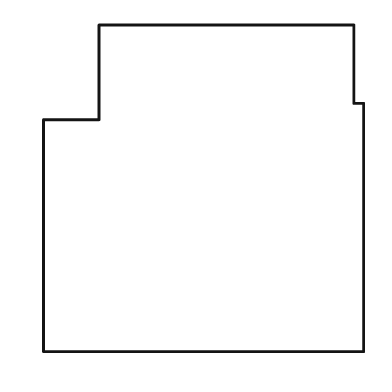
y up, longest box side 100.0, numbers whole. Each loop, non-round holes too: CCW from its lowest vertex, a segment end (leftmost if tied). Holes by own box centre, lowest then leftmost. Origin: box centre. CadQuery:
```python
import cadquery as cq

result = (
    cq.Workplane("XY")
    .moveTo(-49.0, -50.0)
    .lineTo(49.0, -50.0)
    .lineTo(49.0, 26.0)
    .lineTo(46.0, 26.0)
    .lineTo(46.0, 50.0)
    .lineTo(-32.0, 50.0)
    .lineTo(-32.0, 21.0)
    .lineTo(-49.0, 21.0)
    .close()
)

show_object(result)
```